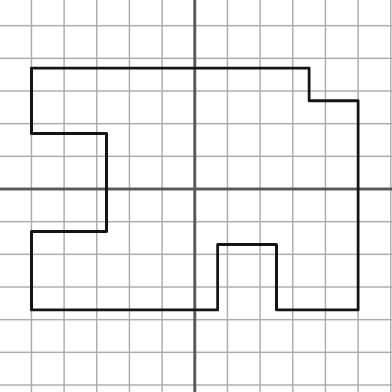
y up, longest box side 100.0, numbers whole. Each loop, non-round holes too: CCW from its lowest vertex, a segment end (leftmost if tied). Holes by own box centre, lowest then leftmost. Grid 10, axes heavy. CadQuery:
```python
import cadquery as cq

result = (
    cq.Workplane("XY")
    .moveTo(-50.0, -37.0)
    .lineTo(7.0, -37.0)
    .lineTo(7.0, -17.0)
    .lineTo(25.0, -17.0)
    .lineTo(25.0, -37.0)
    .lineTo(50.0, -37.0)
    .lineTo(50.0, 27.0)
    .lineTo(35.0, 27.0)
    .lineTo(35.0, 37.0)
    .lineTo(-50.0, 37.0)
    .lineTo(-50.0, 17.0)
    .lineTo(-27.0, 17.0)
    .lineTo(-27.0, -13.0)
    .lineTo(-50.0, -13.0)
    .close()
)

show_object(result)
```